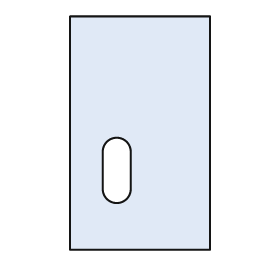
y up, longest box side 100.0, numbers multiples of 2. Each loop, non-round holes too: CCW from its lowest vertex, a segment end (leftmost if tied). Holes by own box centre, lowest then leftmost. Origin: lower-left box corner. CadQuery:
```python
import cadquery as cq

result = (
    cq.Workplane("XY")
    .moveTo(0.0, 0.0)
    .lineTo(60.0, 0.0)
    .lineTo(60.0, 100.0)
    .lineTo(0.0, 100.0)
    .close()
    .moveTo(14.0, 26.0)
    .threePointArc((20.0, 20.0), (26.0, 26.0))
    .lineTo(26.0, 42.0)
    .threePointArc((20.0, 48.0), (14.0, 42.0))
    .close()
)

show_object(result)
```